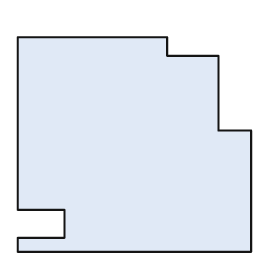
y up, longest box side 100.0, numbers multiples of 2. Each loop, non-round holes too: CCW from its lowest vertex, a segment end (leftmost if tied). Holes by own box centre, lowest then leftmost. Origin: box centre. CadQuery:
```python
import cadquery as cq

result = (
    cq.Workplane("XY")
    .moveTo(-50.0, -46.0)
    .lineTo(50.0, -46.0)
    .lineTo(50.0, 6.0)
    .lineTo(36.0, 6.0)
    .lineTo(36.0, 38.0)
    .lineTo(14.0, 38.0)
    .lineTo(14.0, 46.0)
    .lineTo(-50.0, 46.0)
    .lineTo(-50.0, -28.0)
    .lineTo(-30.0, -28.0)
    .lineTo(-30.0, -40.0)
    .lineTo(-50.0, -40.0)
    .close()
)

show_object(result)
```